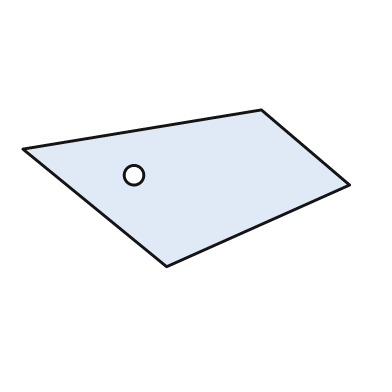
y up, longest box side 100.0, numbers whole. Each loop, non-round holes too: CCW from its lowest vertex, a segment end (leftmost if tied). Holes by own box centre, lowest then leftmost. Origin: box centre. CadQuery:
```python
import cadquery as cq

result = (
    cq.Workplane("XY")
    .moveTo(-6.0, -24.0)
    .lineTo(50.0, 1.0)
    .lineTo(23.0, 24.0)
    .lineTo(-50.0, 12.0)
    .close()
    .moveTo(-16.0, 4.0)
    .circle(3.0)
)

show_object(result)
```